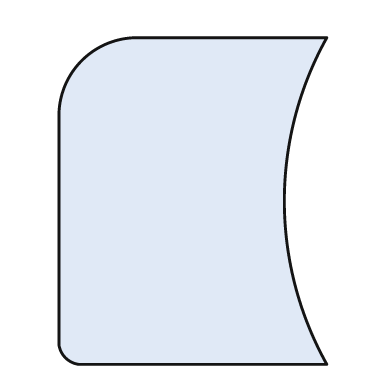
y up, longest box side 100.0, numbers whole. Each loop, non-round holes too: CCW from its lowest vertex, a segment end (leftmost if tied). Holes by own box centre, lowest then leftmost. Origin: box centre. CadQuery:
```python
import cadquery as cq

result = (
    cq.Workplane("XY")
    .moveTo(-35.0, -50.0)
    .lineTo(41.0, -50.0)
    .threePointArc((28.0, 0.0), (41.0, 50.0))
    .lineTo(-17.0, 50.0)
    .threePointArc((-34.0, 43.0), (-41.0, 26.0))
    .lineTo(-41.0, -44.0)
    .threePointArc((-39.0, -48.0), (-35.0, -50.0))
    .close()
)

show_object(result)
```